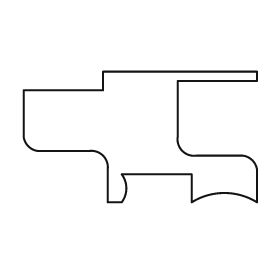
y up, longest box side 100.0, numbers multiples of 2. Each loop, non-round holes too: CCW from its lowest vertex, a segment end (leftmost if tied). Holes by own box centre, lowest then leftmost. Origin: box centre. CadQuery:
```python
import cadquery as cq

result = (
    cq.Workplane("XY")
    .moveTo(-14.0, -28.0)
    .lineTo(-8.0, -28.0)
    .threePointArc((-6.0, -22.0), (-8.0, -16.0))
    .lineTo(22.0, -16.0)
    .lineTo(22.0, -28.0)
    .threePointArc((36.0, -24.0), (50.0, -28.0))
    .lineTo(50.0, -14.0)
    .threePointArc((48.0, -10.0), (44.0, -8.0))
    .lineTo(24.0, -8.0)
    .threePointArc((18.0, -6.0), (16.0, 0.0))
    .lineTo(16.0, 24.0)
    .lineTo(50.0, 24.0)
    .lineTo(50.0, 28.0)
    .lineTo(-16.0, 28.0)
    .lineTo(-16.0, 20.0)
    .lineTo(-50.0, 20.0)
    .lineTo(-50.0, 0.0)
    .threePointArc((-48.0, -4.0), (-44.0, -6.0))
    .lineTo(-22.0, -6.0)
    .threePointArc((-16.0, -8.0), (-14.0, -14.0))
    .close()
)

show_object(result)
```